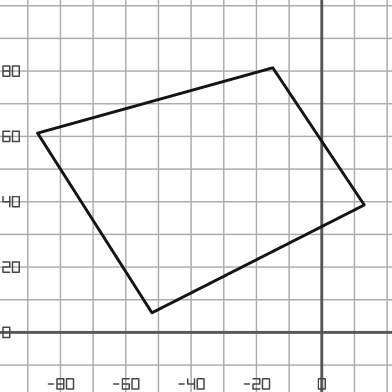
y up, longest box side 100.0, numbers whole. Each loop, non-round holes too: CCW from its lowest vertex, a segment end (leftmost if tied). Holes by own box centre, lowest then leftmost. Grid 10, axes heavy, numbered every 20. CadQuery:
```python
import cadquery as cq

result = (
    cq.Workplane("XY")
    .moveTo(-52.0, 6.0)
    .lineTo(13.0, 39.0)
    .lineTo(-15.0, 81.0)
    .lineTo(-87.0, 61.0)
    .close()
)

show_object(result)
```